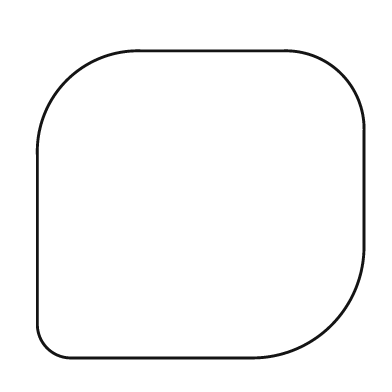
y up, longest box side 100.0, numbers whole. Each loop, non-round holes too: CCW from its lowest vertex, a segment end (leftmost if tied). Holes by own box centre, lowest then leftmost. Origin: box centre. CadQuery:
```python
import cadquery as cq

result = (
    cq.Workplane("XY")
    .moveTo(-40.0, -47.0)
    .lineTo(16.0, -47.0)
    .threePointArc((40.0, -37.0), (50.0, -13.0))
    .lineTo(50.0, 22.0)
    .threePointArc((43.0, 40.0), (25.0, 47.0))
    .lineTo(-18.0, 47.0)
    .threePointArc((-41.0, 38.0), (-50.0, 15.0))
    .lineTo(-50.0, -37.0)
    .threePointArc((-47.0, -44.0), (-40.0, -47.0))
    .close()
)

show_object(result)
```